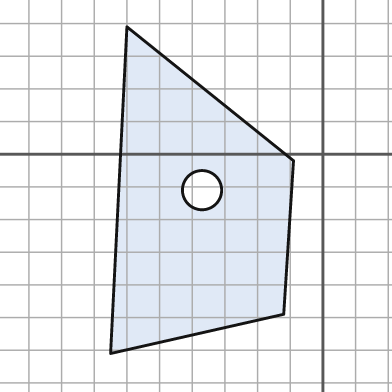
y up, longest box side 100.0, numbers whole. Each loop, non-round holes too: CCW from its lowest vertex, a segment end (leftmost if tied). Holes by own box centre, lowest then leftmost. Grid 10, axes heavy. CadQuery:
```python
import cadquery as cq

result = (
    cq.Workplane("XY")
    .moveTo(-65.0, -61.0)
    .lineTo(-12.0, -49.0)
    .lineTo(-9.0, -2.0)
    .lineTo(-60.0, 39.0)
    .close()
    .moveTo(-37.0, -11.0)
    .circle(6.0)
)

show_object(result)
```